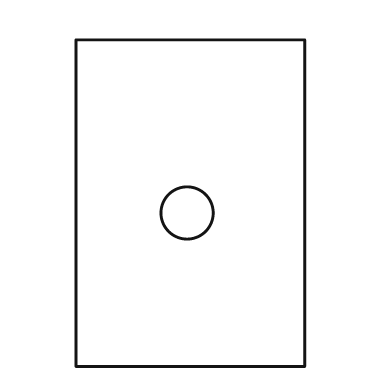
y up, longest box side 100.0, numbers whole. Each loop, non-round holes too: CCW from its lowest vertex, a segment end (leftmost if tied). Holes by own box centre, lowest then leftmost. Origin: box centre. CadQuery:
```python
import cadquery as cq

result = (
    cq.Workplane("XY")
    .moveTo(-35.0, -50.0)
    .lineTo(35.0, -50.0)
    .lineTo(35.0, 50.0)
    .lineTo(-35.0, 50.0)
    .close()
    .moveTo(-1.0, -3.0)
    .circle(8.0)
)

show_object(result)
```